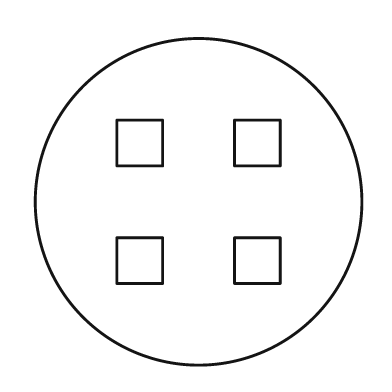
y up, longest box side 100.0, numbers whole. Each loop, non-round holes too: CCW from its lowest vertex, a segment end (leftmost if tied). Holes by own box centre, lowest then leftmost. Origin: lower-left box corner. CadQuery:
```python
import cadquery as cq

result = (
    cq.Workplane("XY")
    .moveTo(50.0, 50.0)
    .circle(50.0)
    .moveTo(25.0, 25.0)
    .lineTo(39.0, 25.0)
    .lineTo(39.0, 39.0)
    .lineTo(25.0, 39.0)
    .close()
    .moveTo(61.0, 25.0)
    .lineTo(75.0, 25.0)
    .lineTo(75.0, 39.0)
    .lineTo(61.0, 39.0)
    .close()
    .moveTo(25.0, 61.0)
    .lineTo(39.0, 61.0)
    .lineTo(39.0, 75.0)
    .lineTo(25.0, 75.0)
    .close()
    .moveTo(61.0, 61.0)
    .lineTo(75.0, 61.0)
    .lineTo(75.0, 75.0)
    .lineTo(61.0, 75.0)
    .close()
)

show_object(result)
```